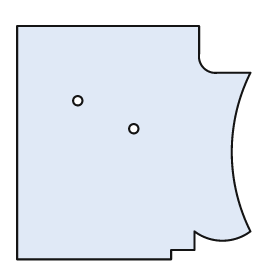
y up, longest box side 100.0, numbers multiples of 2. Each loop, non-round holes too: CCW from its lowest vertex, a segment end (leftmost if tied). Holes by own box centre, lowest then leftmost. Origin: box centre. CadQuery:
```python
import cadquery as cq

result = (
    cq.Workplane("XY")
    .moveTo(-50.0, -50.0)
    .lineTo(16.0, -50.0)
    .lineTo(16.0, -46.0)
    .lineTo(26.0, -46.0)
    .lineTo(26.0, -38.0)
    .threePointArc((38.0, -42.0), (50.0, -38.0))
    .threePointArc((42.0, -4.0), (50.0, 30.0))
    .lineTo(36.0, 30.0)
    .threePointArc((30.0, 32.0), (28.0, 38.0))
    .lineTo(28.0, 50.0)
    .lineTo(-50.0, 50.0)
    .close()
    .moveTo(0.0, 6.0)
    .circle(2.0)
    .moveTo(-24.0, 18.0)
    .circle(2.0)
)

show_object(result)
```